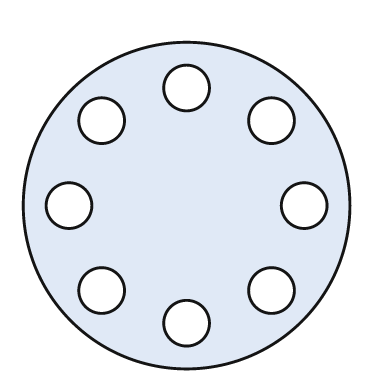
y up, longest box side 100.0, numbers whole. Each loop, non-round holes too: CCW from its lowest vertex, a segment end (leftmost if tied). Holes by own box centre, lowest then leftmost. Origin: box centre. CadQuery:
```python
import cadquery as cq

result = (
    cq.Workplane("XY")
    .moveTo(0.0, 0.0)
    .circle(50.0)
    .moveTo(0.0, -36.0)
    .circle(7.0)
    .moveTo(-26.0, -26.0)
    .circle(7.0)
    .moveTo(26.0, -26.0)
    .circle(7.0)
    .moveTo(-36.0, 0.0)
    .circle(7.0)
    .moveTo(36.0, 0.0)
    .circle(7.0)
    .moveTo(-26.0, 26.0)
    .circle(7.0)
    .moveTo(26.0, 26.0)
    .circle(7.0)
    .moveTo(0.0, 36.0)
    .circle(7.0)
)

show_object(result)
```